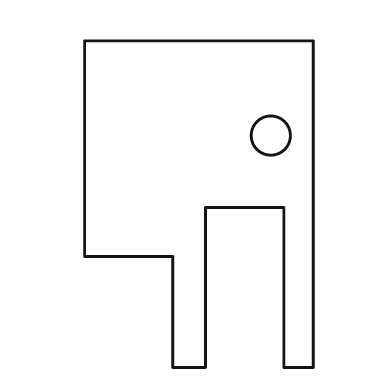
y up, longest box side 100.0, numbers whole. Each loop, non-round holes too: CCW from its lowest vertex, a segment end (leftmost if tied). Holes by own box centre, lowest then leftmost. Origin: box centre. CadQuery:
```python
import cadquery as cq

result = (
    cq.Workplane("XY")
    .moveTo(-8.0, -50.0)
    .lineTo(2.0, -50.0)
    .lineTo(2.0, -1.0)
    .lineTo(26.0, -1.0)
    .lineTo(26.0, -50.0)
    .lineTo(35.0, -50.0)
    .lineTo(35.0, 50.0)
    .lineTo(-35.0, 50.0)
    .lineTo(-35.0, -16.0)
    .lineTo(-8.0, -16.0)
    .close()
    .moveTo(22.0, 21.0)
    .circle(6.0)
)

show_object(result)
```